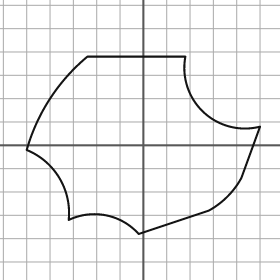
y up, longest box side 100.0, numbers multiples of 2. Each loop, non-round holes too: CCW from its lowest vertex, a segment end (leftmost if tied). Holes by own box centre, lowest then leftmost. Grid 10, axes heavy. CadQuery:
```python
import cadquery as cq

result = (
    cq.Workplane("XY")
    .moveTo(-2.0, -38.0)
    .lineTo(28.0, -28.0)
    .threePointArc((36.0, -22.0), (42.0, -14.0))
    .lineTo(50.0, 8.0)
    .threePointArc((26.0, 14.0), (18.0, 38.0))
    .lineTo(-24.0, 38.0)
    .threePointArc((-40.0, 20.0), (-50.0, -2.0))
    .threePointArc((-36.0, -14.0), (-32.0, -32.0))
    .threePointArc((-16.0, -30.0), (-2.0, -38.0))
    .close()
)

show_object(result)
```